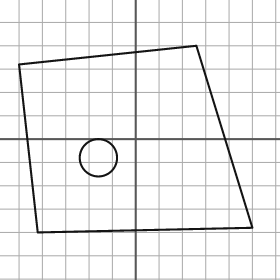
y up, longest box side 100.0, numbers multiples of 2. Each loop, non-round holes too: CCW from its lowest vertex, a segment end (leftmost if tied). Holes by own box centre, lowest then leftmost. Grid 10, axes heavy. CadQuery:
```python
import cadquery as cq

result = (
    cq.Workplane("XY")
    .moveTo(-42.0, -40.0)
    .lineTo(50.0, -38.0)
    .lineTo(26.0, 40.0)
    .lineTo(-50.0, 32.0)
    .close()
    .moveTo(-16.0, -8.0)
    .circle(8.0)
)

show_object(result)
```